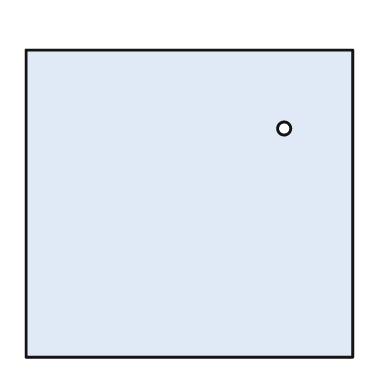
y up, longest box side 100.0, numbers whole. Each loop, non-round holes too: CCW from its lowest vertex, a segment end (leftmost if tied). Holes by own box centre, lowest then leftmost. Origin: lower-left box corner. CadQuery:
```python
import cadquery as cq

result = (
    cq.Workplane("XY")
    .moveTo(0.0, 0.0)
    .lineTo(100.0, 0.0)
    .lineTo(100.0, 94.0)
    .lineTo(0.0, 94.0)
    .close()
    .moveTo(79.0, 70.0)
    .circle(2.0)
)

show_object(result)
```